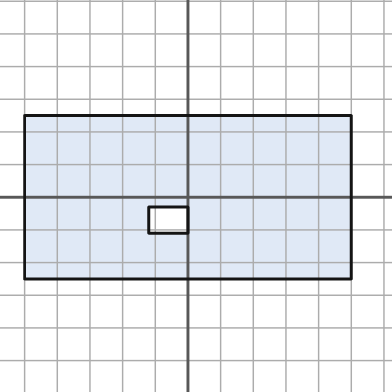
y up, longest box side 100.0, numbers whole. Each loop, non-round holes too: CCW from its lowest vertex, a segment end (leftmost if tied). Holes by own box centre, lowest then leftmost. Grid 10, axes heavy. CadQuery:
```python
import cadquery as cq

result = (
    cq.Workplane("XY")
    .moveTo(-50.0, -25.0)
    .lineTo(50.0, -25.0)
    .lineTo(50.0, 25.0)
    .lineTo(-50.0, 25.0)
    .close()
    .moveTo(-12.0, -11.0)
    .lineTo(0.0, -11.0)
    .lineTo(0.0, -3.0)
    .lineTo(-12.0, -3.0)
    .close()
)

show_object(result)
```